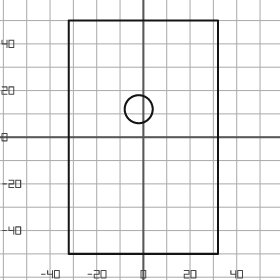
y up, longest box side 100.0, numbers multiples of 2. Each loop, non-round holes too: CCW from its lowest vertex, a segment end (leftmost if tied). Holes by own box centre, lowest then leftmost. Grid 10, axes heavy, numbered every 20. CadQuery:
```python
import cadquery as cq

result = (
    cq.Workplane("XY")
    .moveTo(-32.0, -50.0)
    .lineTo(32.0, -50.0)
    .lineTo(32.0, 50.0)
    .lineTo(-32.0, 50.0)
    .close()
    .moveTo(-2.0, 12.0)
    .circle(6.0)
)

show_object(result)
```